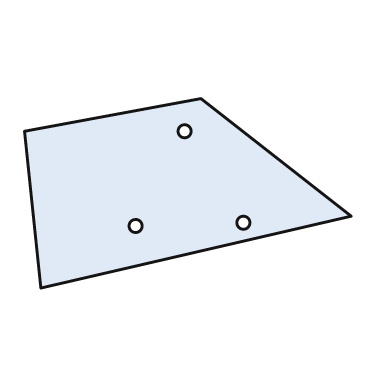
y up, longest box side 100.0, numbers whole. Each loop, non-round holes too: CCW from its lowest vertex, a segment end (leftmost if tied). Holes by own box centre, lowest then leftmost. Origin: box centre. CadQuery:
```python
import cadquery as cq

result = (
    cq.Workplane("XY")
    .moveTo(-45.0, -29.0)
    .lineTo(50.0, -7.0)
    .lineTo(4.0, 29.0)
    .lineTo(-50.0, 19.0)
    .close()
    .moveTo(-16.0, -10.0)
    .circle(2.0)
    .moveTo(17.0, -9.0)
    .circle(2.0)
    .moveTo(-1.0, 19.0)
    .circle(2.0)
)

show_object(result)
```